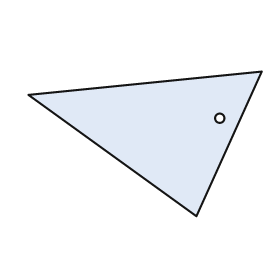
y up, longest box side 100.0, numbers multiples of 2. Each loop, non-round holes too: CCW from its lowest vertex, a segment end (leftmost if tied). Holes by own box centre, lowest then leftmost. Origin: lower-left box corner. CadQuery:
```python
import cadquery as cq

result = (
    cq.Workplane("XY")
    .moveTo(72.0, 0.0)
    .lineTo(100.0, 62.0)
    .lineTo(0.0, 52.0)
    .close()
    .moveTo(82.0, 42.0)
    .circle(2.0)
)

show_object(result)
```